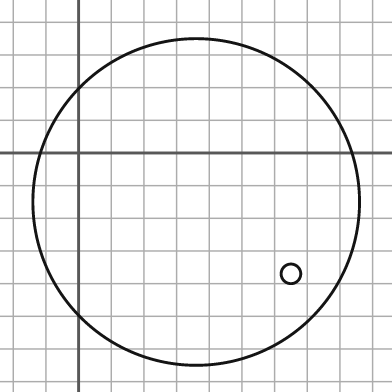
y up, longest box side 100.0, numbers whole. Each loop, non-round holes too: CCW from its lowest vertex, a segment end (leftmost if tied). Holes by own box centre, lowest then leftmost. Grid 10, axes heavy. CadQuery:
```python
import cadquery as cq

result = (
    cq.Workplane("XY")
    .moveTo(36.0, -15.0)
    .circle(50.0)
    .moveTo(65.0, -37.0)
    .circle(3.0)
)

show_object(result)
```